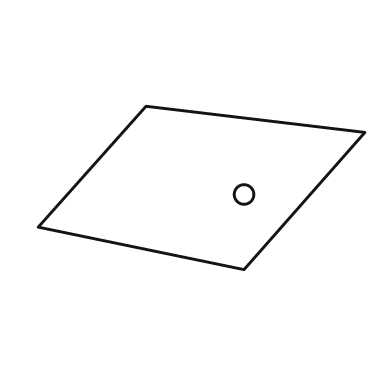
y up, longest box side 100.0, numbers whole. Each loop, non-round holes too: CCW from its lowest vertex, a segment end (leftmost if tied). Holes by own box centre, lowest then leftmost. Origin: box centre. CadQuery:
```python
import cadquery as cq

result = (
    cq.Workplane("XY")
    .moveTo(13.0, -25.0)
    .lineTo(50.0, 17.0)
    .lineTo(-17.0, 25.0)
    .lineTo(-50.0, -12.0)
    .close()
    .moveTo(13.0, -2.0)
    .circle(3.0)
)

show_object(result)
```